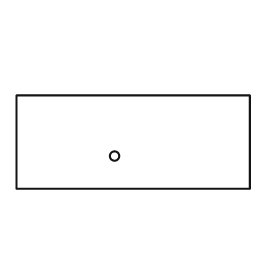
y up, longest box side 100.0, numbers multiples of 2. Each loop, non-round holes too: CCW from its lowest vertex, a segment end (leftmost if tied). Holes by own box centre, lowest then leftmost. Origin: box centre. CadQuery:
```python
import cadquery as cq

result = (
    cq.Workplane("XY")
    .moveTo(-50.0, -20.0)
    .lineTo(50.0, -20.0)
    .lineTo(50.0, 20.0)
    .lineTo(-50.0, 20.0)
    .close()
    .moveTo(-8.0, -6.0)
    .circle(2.0)
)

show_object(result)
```